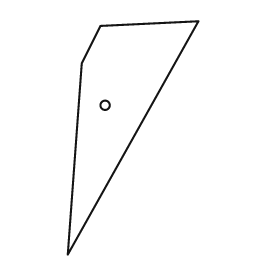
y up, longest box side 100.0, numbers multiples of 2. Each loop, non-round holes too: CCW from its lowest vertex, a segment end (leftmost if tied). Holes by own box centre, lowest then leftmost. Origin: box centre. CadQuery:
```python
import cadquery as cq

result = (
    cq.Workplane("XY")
    .moveTo(-28.0, -50.0)
    .lineTo(28.0, 50.0)
    .lineTo(-14.0, 48.0)
    .lineTo(-22.0, 32.0)
    .close()
    .moveTo(-12.0, 14.0)
    .circle(2.0)
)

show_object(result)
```